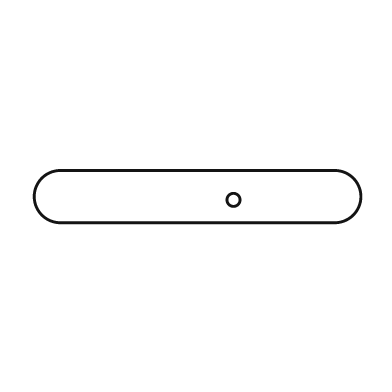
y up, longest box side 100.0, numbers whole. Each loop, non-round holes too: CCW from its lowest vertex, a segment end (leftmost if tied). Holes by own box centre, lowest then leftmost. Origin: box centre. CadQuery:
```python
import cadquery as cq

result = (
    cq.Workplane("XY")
    .moveTo(-42.0, -8.0)
    .lineTo(42.0, -8.0)
    .threePointArc((50.0, 0.0), (42.0, 8.0))
    .lineTo(-42.0, 8.0)
    .threePointArc((-50.0, 0.0), (-42.0, -8.0))
    .close()
    .moveTo(11.0, -1.0)
    .circle(2.0)
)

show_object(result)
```